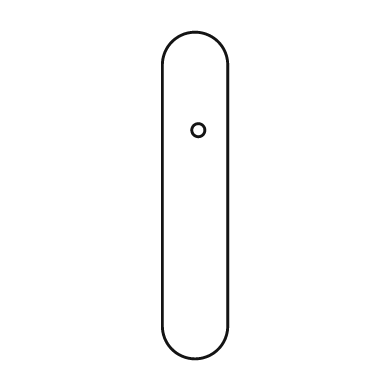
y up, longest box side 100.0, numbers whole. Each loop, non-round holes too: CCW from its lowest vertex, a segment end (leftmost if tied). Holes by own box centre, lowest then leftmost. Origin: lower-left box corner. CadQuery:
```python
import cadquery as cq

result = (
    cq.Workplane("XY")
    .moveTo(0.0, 10.0)
    .threePointArc((10.0, 0.0), (20.0, 10.0))
    .lineTo(20.0, 90.0)
    .threePointArc((10.0, 100.0), (0.0, 90.0))
    .close()
    .moveTo(11.0, 70.0)
    .circle(2.0)
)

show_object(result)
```